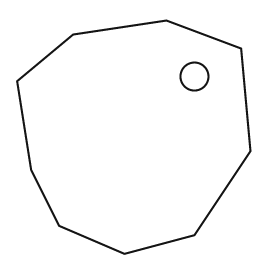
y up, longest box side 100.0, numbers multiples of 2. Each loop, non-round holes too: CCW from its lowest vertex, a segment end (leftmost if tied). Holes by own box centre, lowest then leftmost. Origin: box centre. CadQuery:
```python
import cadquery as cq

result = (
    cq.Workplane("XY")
    .moveTo(-4.0, -50.0)
    .lineTo(26.0, -42.0)
    .lineTo(50.0, -6.0)
    .lineTo(46.0, 38.0)
    .lineTo(14.0, 50.0)
    .lineTo(-26.0, 44.0)
    .lineTo(-50.0, 24.0)
    .lineTo(-44.0, -14.0)
    .lineTo(-32.0, -38.0)
    .close()
    .moveTo(26.0, 26.0)
    .circle(6.0)
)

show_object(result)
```